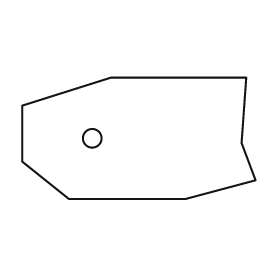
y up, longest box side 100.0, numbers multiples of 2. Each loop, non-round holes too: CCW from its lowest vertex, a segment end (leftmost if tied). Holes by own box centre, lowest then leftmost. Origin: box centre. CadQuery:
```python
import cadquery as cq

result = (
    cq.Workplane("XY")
    .moveTo(-30.0, -26.0)
    .lineTo(20.0, -26.0)
    .lineTo(50.0, -18.0)
    .lineTo(44.0, -2.0)
    .lineTo(46.0, 26.0)
    .lineTo(-12.0, 26.0)
    .lineTo(-50.0, 14.0)
    .lineTo(-50.0, -10.0)
    .close()
    .moveTo(-20.0, 0.0)
    .circle(4.0)
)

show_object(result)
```